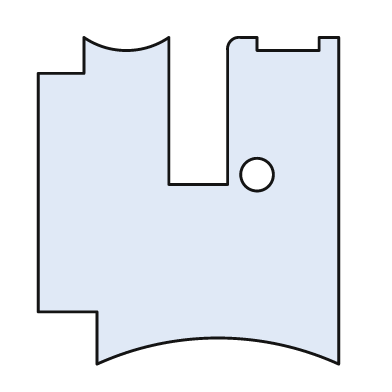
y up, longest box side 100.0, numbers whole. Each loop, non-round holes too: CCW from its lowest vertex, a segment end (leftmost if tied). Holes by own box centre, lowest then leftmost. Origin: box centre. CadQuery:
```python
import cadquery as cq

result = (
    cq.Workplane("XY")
    .moveTo(-28.0, -50.0)
    .threePointArc((9.0, -42.0), (46.0, -50.0))
    .lineTo(46.0, 50.0)
    .lineTo(40.0, 50.0)
    .lineTo(40.0, 46.0)
    .lineTo(21.0, 46.0)
    .lineTo(21.0, 50.0)
    .lineTo(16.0, 50.0)
    .threePointArc((13.0, 49.0), (12.0, 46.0))
    .lineTo(12.0, 5.0)
    .lineTo(-6.0, 5.0)
    .lineTo(-6.0, 50.0)
    .threePointArc((-19.0, 46.0), (-32.0, 50.0))
    .lineTo(-32.0, 39.0)
    .lineTo(-46.0, 39.0)
    .lineTo(-46.0, -34.0)
    .lineTo(-28.0, -34.0)
    .close()
    .moveTo(21.0, 8.0)
    .circle(5.0)
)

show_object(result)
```